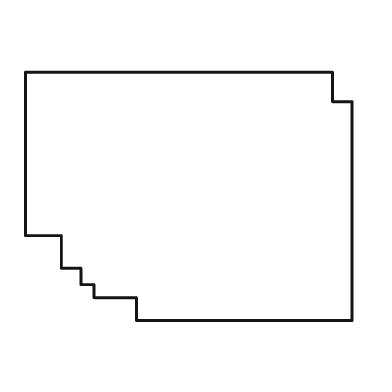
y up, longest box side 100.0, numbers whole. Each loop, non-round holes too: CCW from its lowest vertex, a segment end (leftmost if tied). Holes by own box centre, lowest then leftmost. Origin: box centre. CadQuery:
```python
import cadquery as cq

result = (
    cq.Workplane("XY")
    .moveTo(-16.0, -38.0)
    .lineTo(50.0, -38.0)
    .lineTo(50.0, 29.0)
    .lineTo(44.0, 29.0)
    .lineTo(44.0, 38.0)
    .lineTo(-50.0, 38.0)
    .lineTo(-50.0, -12.0)
    .lineTo(-39.0, -12.0)
    .lineTo(-39.0, -22.0)
    .lineTo(-33.0, -22.0)
    .lineTo(-33.0, -27.0)
    .lineTo(-29.0, -27.0)
    .lineTo(-29.0, -31.0)
    .lineTo(-16.0, -31.0)
    .close()
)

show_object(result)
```